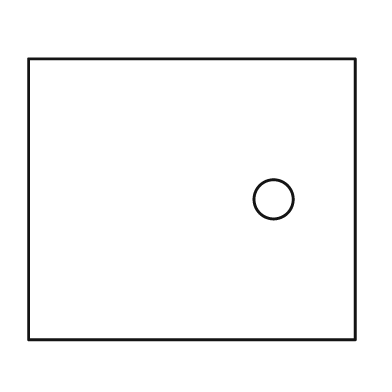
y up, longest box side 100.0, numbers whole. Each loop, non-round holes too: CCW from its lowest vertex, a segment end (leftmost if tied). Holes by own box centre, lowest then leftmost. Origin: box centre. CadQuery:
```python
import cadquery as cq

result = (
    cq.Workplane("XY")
    .moveTo(-50.0, -43.0)
    .lineTo(50.0, -43.0)
    .lineTo(50.0, 43.0)
    .lineTo(-50.0, 43.0)
    .close()
    .moveTo(25.0, 0.0)
    .circle(6.0)
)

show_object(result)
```